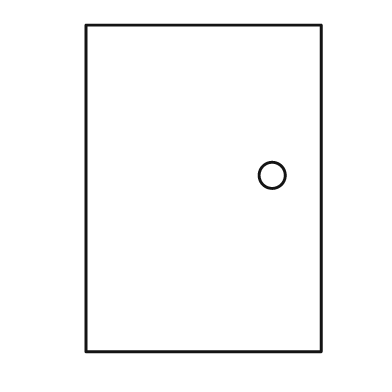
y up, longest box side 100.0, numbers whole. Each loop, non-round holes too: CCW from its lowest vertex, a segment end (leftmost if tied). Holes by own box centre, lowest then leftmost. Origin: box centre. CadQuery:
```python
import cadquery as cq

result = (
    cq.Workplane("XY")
    .moveTo(-36.0, -50.0)
    .lineTo(36.0, -50.0)
    .lineTo(36.0, 50.0)
    .lineTo(-36.0, 50.0)
    .close()
    .moveTo(21.0, 4.0)
    .circle(4.0)
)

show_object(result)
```